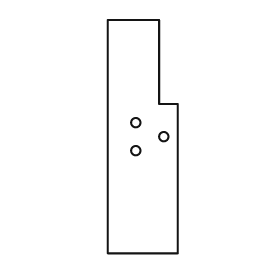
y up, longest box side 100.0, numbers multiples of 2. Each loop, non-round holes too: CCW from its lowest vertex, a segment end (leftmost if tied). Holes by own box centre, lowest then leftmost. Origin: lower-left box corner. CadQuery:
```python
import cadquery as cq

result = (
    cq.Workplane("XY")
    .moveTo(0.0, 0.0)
    .lineTo(30.0, 0.0)
    .lineTo(30.0, 64.0)
    .lineTo(22.0, 64.0)
    .lineTo(22.0, 100.0)
    .lineTo(0.0, 100.0)
    .close()
    .moveTo(12.0, 44.0)
    .circle(2.0)
    .moveTo(24.0, 50.0)
    .circle(2.0)
    .moveTo(12.0, 56.0)
    .circle(2.0)
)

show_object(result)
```